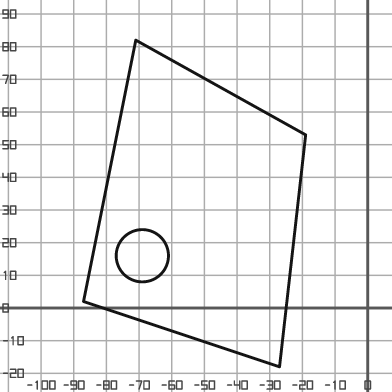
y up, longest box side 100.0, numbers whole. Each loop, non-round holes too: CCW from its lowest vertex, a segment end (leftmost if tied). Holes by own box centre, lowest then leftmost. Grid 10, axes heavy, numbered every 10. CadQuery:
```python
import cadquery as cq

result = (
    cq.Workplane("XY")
    .moveTo(-27.0, -18.0)
    .lineTo(-19.0, 53.0)
    .lineTo(-71.0, 82.0)
    .lineTo(-87.0, 2.0)
    .close()
    .moveTo(-69.0, 16.0)
    .circle(8.0)
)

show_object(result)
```